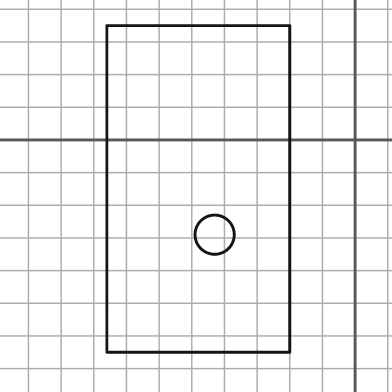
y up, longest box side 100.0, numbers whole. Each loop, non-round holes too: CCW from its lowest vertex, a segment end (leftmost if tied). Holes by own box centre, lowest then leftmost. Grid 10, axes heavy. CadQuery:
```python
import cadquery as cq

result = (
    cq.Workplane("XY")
    .moveTo(-76.0, -65.0)
    .lineTo(-20.0, -65.0)
    .lineTo(-20.0, 35.0)
    .lineTo(-76.0, 35.0)
    .close()
    .moveTo(-43.0, -29.0)
    .circle(6.0)
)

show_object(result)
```